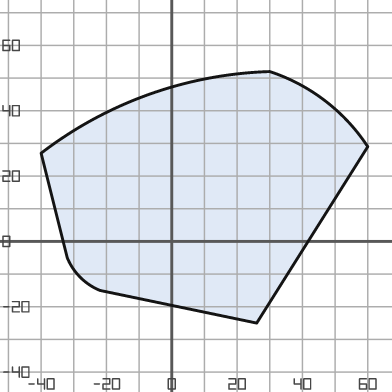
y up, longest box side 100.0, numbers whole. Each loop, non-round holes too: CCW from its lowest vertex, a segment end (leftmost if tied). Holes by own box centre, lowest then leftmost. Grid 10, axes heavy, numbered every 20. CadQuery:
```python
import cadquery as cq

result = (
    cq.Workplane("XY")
    .moveTo(26.0, -25.0)
    .lineTo(60.0, 29.0)
    .threePointArc((47.0, 43.0), (30.0, 52.0))
    .threePointArc((-7.0, 45.0), (-40.0, 27.0))
    .lineTo(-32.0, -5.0)
    .threePointArc((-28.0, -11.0), (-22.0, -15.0))
    .close()
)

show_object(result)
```